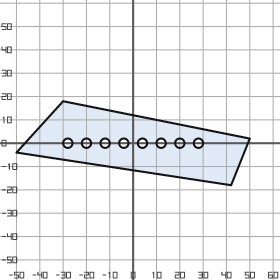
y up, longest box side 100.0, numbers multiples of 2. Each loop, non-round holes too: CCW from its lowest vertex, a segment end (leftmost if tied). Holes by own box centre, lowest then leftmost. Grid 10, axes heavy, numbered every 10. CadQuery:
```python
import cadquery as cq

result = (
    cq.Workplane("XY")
    .moveTo(42.0, -18.0)
    .lineTo(50.0, 2.0)
    .lineTo(-30.0, 18.0)
    .lineTo(-50.0, -4.0)
    .close()
    .moveTo(-28.0, 0.0)
    .circle(2.0)
    .moveTo(-20.0, 0.0)
    .circle(2.0)
    .moveTo(-12.0, 0.0)
    .circle(2.0)
    .moveTo(-4.0, 0.0)
    .circle(2.0)
    .moveTo(4.0, 0.0)
    .circle(2.0)
    .moveTo(12.0, 0.0)
    .circle(2.0)
    .moveTo(20.0, 0.0)
    .circle(2.0)
    .moveTo(28.0, 0.0)
    .circle(2.0)
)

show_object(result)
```